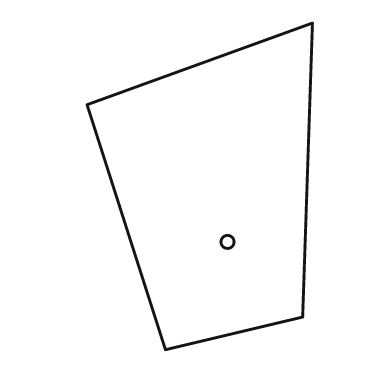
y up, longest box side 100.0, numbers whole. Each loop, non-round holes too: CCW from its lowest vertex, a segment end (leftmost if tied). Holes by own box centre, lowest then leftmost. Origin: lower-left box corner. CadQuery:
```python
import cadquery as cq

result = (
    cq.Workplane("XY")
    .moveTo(24.0, 0.0)
    .lineTo(66.0, 10.0)
    .lineTo(69.0, 100.0)
    .lineTo(0.0, 75.0)
    .close()
    .moveTo(43.0, 33.0)
    .circle(2.0)
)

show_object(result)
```